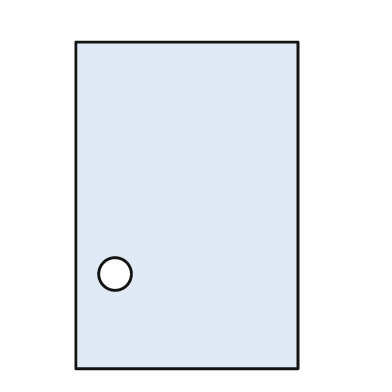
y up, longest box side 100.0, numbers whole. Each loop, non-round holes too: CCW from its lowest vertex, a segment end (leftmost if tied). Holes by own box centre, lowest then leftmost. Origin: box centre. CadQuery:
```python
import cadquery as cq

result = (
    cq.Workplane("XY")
    .moveTo(-34.0, -50.0)
    .lineTo(34.0, -50.0)
    .lineTo(34.0, 50.0)
    .lineTo(-34.0, 50.0)
    .close()
    .moveTo(-22.0, -21.0)
    .circle(5.0)
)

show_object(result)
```